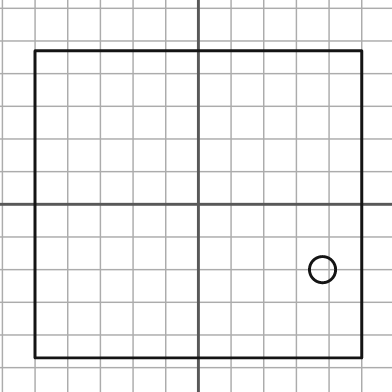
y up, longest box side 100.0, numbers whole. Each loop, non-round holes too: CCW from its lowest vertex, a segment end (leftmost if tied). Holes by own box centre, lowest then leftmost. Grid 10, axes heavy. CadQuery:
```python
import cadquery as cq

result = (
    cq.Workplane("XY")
    .moveTo(-50.0, -47.0)
    .lineTo(50.0, -47.0)
    .lineTo(50.0, 47.0)
    .lineTo(-50.0, 47.0)
    .close()
    .moveTo(38.0, -20.0)
    .circle(4.0)
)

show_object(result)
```